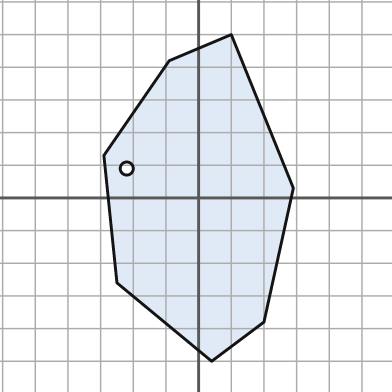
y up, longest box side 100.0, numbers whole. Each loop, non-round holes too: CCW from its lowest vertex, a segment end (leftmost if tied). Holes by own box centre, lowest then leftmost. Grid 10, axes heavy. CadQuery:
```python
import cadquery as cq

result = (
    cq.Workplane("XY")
    .moveTo(4.0, -50.0)
    .lineTo(20.0, -38.0)
    .lineTo(29.0, 3.0)
    .lineTo(10.0, 50.0)
    .lineTo(-9.0, 42.0)
    .lineTo(-29.0, 13.0)
    .lineTo(-25.0, -26.0)
    .close()
    .moveTo(-22.0, 9.0)
    .circle(2.0)
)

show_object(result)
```